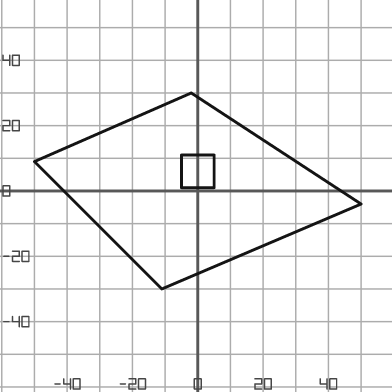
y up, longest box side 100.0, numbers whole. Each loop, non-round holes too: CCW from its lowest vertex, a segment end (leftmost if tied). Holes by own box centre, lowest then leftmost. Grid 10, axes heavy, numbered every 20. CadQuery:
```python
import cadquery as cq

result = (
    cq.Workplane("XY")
    .moveTo(-11.0, -30.0)
    .lineTo(50.0, -4.0)
    .lineTo(-2.0, 30.0)
    .lineTo(-50.0, 9.0)
    .close()
    .moveTo(-5.0, 1.0)
    .lineTo(5.0, 1.0)
    .lineTo(5.0, 11.0)
    .lineTo(-5.0, 11.0)
    .close()
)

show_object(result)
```